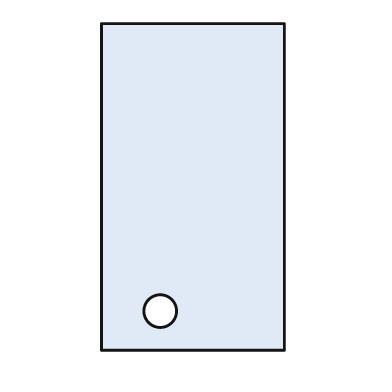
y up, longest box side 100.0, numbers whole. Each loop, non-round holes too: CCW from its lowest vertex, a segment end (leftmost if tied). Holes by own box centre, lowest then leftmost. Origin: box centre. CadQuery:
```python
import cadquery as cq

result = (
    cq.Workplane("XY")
    .moveTo(-28.0, -50.0)
    .lineTo(28.0, -50.0)
    .lineTo(28.0, 50.0)
    .lineTo(-28.0, 50.0)
    .close()
    .moveTo(-10.0, -38.0)
    .circle(5.0)
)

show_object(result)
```